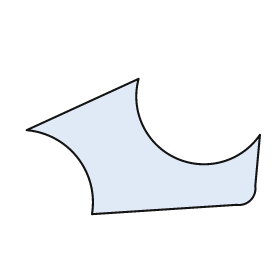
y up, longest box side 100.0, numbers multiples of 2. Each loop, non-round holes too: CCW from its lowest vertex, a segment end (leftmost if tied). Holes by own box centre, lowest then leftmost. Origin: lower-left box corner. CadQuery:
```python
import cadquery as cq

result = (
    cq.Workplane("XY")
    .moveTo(28.0, 0.0)
    .lineTo(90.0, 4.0)
    .threePointArc((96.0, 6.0), (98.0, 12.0))
    .lineTo(100.0, 34.0)
    .threePointArc((64.0, 24.0), (48.0, 58.0))
    .lineTo(0.0, 36.0)
    .threePointArc((22.0, 24.0), (28.0, 0.0))
    .close()
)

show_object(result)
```